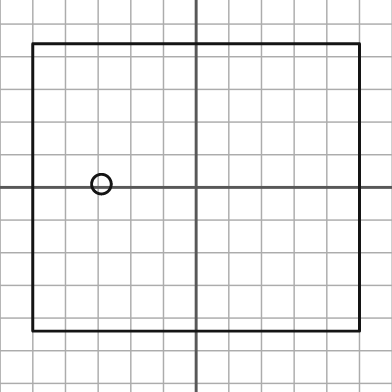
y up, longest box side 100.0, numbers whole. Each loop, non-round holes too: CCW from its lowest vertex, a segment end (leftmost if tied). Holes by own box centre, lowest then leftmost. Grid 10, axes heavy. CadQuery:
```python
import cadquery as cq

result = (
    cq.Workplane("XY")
    .moveTo(-50.0, -44.0)
    .lineTo(50.0, -44.0)
    .lineTo(50.0, 44.0)
    .lineTo(-50.0, 44.0)
    .close()
    .moveTo(-29.0, 1.0)
    .circle(3.0)
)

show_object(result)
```